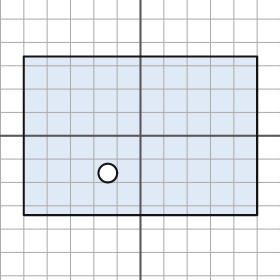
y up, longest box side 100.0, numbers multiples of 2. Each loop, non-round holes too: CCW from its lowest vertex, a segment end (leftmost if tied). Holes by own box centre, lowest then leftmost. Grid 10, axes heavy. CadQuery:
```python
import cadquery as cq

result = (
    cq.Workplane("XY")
    .moveTo(-50.0, -34.0)
    .lineTo(50.0, -34.0)
    .lineTo(50.0, 34.0)
    .lineTo(-50.0, 34.0)
    .close()
    .moveTo(-14.0, -16.0)
    .circle(4.0)
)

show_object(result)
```